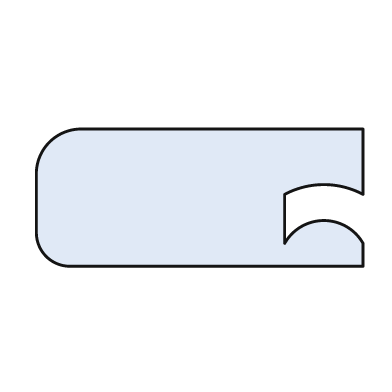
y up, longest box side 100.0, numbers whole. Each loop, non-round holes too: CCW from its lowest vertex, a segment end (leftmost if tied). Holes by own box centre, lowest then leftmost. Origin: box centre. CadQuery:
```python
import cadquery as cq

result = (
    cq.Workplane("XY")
    .moveTo(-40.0, -21.0)
    .lineTo(50.0, -21.0)
    .lineTo(50.0, -14.0)
    .threePointArc((38.0, -7.0), (26.0, -14.0))
    .lineTo(26.0, 1.0)
    .threePointArc((38.0, 4.0), (50.0, 1.0))
    .lineTo(50.0, 21.0)
    .lineTo(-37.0, 21.0)
    .threePointArc((-46.0, 17.0), (-50.0, 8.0))
    .lineTo(-50.0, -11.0)
    .threePointArc((-47.0, -18.0), (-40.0, -21.0))
    .close()
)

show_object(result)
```